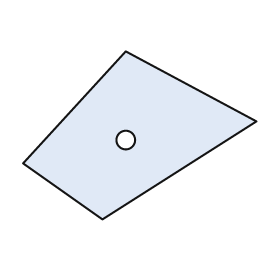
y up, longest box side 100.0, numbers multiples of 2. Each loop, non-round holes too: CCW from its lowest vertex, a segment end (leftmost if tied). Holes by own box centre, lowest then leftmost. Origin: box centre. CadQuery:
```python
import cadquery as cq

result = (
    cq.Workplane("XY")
    .moveTo(-16.0, -36.0)
    .lineTo(50.0, 6.0)
    .lineTo(-6.0, 36.0)
    .lineTo(-50.0, -12.0)
    .close()
    .moveTo(-6.0, -2.0)
    .circle(4.0)
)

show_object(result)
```